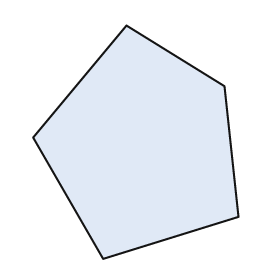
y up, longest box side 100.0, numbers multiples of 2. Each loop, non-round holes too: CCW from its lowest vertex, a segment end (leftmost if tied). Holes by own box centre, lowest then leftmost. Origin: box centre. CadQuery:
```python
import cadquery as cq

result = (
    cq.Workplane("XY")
    .moveTo(-14.0, -50.0)
    .lineTo(44.0, -32.0)
    .lineTo(38.0, 24.0)
    .lineTo(-4.0, 50.0)
    .lineTo(-44.0, 2.0)
    .close()
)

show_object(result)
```